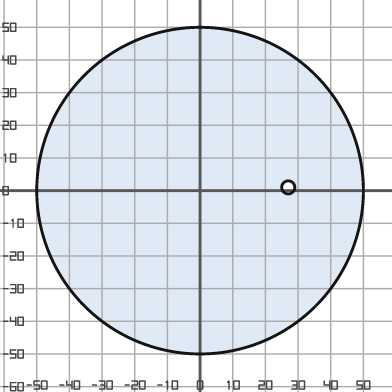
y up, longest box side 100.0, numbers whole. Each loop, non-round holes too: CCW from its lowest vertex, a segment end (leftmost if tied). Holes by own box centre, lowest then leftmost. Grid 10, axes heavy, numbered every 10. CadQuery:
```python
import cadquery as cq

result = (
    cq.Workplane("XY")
    .moveTo(0.0, 0.0)
    .circle(50.0)
    .moveTo(27.0, 1.0)
    .circle(2.0)
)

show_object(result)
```